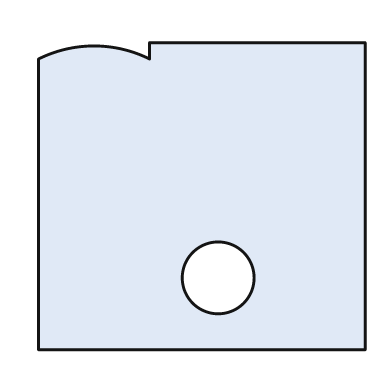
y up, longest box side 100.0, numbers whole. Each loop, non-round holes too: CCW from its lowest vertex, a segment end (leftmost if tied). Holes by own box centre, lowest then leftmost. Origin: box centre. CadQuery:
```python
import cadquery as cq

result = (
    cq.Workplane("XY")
    .moveTo(-50.0, -47.0)
    .lineTo(50.0, -47.0)
    .lineTo(50.0, 47.0)
    .lineTo(-16.0, 47.0)
    .lineTo(-16.0, 42.0)
    .threePointArc((-33.0, 46.0), (-50.0, 42.0))
    .close()
    .moveTo(5.0, -25.0)
    .circle(11.0)
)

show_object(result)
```